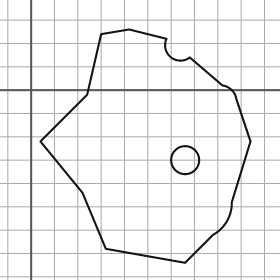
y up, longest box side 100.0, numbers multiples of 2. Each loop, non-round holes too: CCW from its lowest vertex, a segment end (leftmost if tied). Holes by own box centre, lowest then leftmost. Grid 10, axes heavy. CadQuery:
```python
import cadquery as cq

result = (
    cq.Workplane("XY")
    .moveTo(66.0, -74.0)
    .lineTo(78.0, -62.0)
    .threePointArc((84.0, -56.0), (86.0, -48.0))
    .lineTo(94.0, -22.0)
    .lineTo(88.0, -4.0)
    .threePointArc((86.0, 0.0), (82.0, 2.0))
    .lineTo(68.0, 14.0)
    .threePointArc((60.0, 14.0), (58.0, 22.0))
    .lineTo(42.0, 26.0)
    .lineTo(30.0, 24.0)
    .lineTo(24.0, -2.0)
    .lineTo(4.0, -22.0)
    .lineTo(22.0, -44.0)
    .lineTo(32.0, -68.0)
    .close()
    .moveTo(66.0, -30.0)
    .circle(6.0)
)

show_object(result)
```